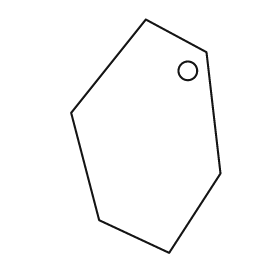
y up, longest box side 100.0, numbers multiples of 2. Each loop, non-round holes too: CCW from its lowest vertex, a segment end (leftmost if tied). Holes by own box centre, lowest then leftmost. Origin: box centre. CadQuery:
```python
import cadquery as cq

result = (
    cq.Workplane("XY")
    .moveTo(10.0, -50.0)
    .lineTo(32.0, -16.0)
    .lineTo(26.0, 36.0)
    .lineTo(0.0, 50.0)
    .lineTo(-32.0, 10.0)
    .lineTo(-20.0, -36.0)
    .close()
    .moveTo(18.0, 28.0)
    .circle(4.0)
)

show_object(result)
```